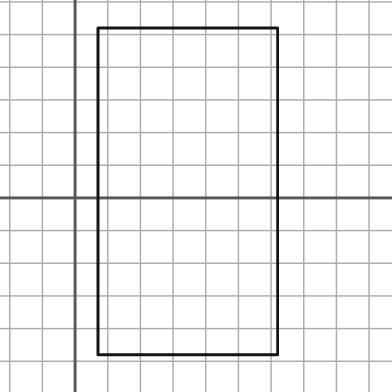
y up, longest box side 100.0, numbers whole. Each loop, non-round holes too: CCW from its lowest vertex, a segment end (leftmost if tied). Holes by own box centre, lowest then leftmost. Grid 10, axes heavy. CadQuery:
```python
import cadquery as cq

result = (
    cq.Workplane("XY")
    .moveTo(7.0, -48.0)
    .lineTo(62.0, -48.0)
    .lineTo(62.0, 52.0)
    .lineTo(7.0, 52.0)
    .close()
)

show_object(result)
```